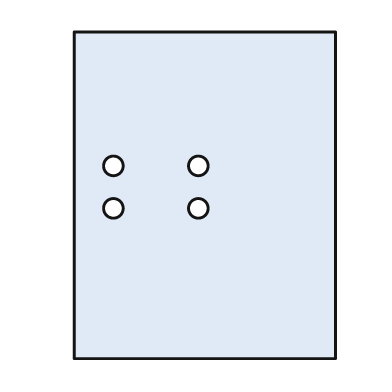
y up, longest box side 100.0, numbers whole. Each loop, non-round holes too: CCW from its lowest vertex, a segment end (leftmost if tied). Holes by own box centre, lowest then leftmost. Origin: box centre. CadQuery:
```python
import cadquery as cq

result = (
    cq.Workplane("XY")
    .moveTo(-40.0, -50.0)
    .lineTo(40.0, -50.0)
    .lineTo(40.0, 50.0)
    .lineTo(-40.0, 50.0)
    .close()
    .moveTo(-28.0, -4.0)
    .circle(3.0)
    .moveTo(-2.0, -4.0)
    .circle(3.0)
    .moveTo(-28.0, 9.0)
    .circle(3.0)
    .moveTo(-2.0, 9.0)
    .circle(3.0)
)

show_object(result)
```